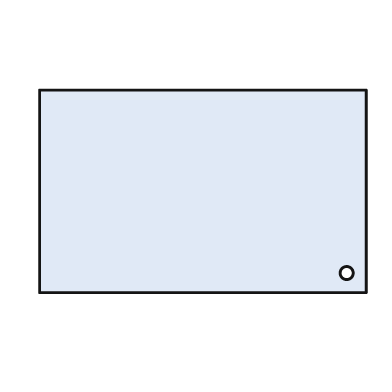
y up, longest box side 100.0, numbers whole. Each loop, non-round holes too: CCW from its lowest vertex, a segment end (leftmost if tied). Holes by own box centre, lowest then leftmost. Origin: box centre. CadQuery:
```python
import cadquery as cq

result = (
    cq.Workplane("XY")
    .moveTo(-50.0, -31.0)
    .lineTo(50.0, -31.0)
    .lineTo(50.0, 31.0)
    .lineTo(-50.0, 31.0)
    .close()
    .moveTo(44.0, -25.0)
    .circle(2.0)
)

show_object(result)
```